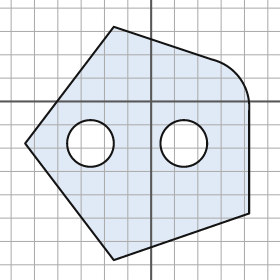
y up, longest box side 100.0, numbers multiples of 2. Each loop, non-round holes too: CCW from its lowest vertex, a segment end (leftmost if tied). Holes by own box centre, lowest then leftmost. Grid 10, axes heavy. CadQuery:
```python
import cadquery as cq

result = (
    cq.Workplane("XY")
    .moveTo(-16.0, -68.0)
    .lineTo(42.0, -48.0)
    .lineTo(42.0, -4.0)
    .threePointArc((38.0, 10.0), (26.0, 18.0))
    .lineTo(-16.0, 32.0)
    .lineTo(-54.0, -18.0)
    .close()
    .moveTo(-26.0, -18.0)
    .circle(10.0)
    .moveTo(14.0, -18.0)
    .circle(10.0)
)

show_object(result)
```